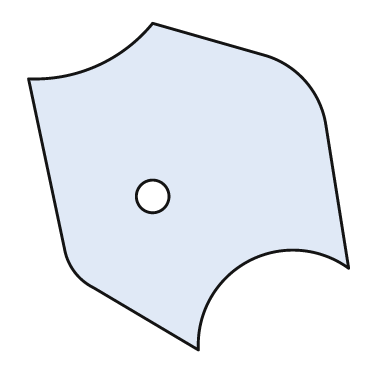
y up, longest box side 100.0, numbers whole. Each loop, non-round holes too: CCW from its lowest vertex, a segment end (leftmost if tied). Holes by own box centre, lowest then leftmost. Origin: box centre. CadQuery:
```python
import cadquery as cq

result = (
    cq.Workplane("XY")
    .moveTo(3.0, -50.0)
    .threePointArc((18.0, -23.0), (49.0, -25.0))
    .lineTo(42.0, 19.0)
    .threePointArc((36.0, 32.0), (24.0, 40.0))
    .lineTo(-11.0, 50.0)
    .threePointArc((-28.0, 37.0), (-49.0, 33.0))
    .lineTo(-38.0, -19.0)
    .threePointArc((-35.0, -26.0), (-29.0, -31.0))
    .close()
    .moveTo(-11.0, -3.0)
    .circle(5.0)
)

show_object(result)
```